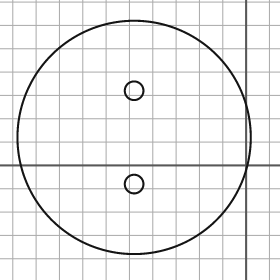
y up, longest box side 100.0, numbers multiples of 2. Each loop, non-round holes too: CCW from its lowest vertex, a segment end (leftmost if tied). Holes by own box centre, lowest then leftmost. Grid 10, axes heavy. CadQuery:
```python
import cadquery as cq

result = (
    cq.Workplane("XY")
    .moveTo(-48.0, 12.0)
    .circle(50.0)
    .moveTo(-48.0, -8.0)
    .circle(4.0)
    .moveTo(-48.0, 32.0)
    .circle(4.0)
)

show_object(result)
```